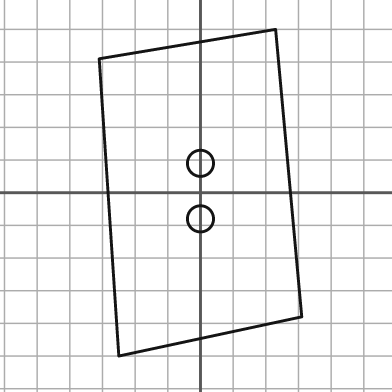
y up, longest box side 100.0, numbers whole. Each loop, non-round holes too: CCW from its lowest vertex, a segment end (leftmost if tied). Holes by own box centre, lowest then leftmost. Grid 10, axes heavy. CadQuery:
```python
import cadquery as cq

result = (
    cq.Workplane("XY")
    .moveTo(-25.0, -50.0)
    .lineTo(31.0, -38.0)
    .lineTo(23.0, 50.0)
    .lineTo(-31.0, 41.0)
    .close()
    .moveTo(0.0, -8.0)
    .circle(4.0)
    .moveTo(0.0, 9.0)
    .circle(4.0)
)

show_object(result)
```